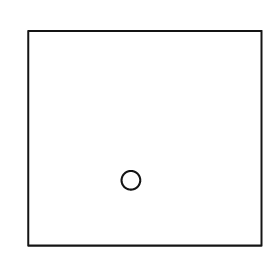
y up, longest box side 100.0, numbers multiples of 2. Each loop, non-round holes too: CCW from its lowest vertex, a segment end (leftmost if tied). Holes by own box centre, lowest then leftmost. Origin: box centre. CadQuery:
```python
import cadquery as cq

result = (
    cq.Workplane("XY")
    .moveTo(-50.0, -46.0)
    .lineTo(50.0, -46.0)
    .lineTo(50.0, 46.0)
    .lineTo(-50.0, 46.0)
    .close()
    .moveTo(-6.0, -18.0)
    .circle(4.0)
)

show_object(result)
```